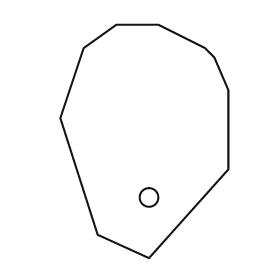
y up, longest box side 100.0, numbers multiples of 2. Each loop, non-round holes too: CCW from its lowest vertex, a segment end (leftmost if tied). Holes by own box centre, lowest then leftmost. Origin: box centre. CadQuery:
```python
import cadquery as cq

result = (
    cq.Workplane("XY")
    .moveTo(2.0, -50.0)
    .lineTo(36.0, -12.0)
    .lineTo(36.0, 22.0)
    .lineTo(30.0, 36.0)
    .lineTo(26.0, 40.0)
    .lineTo(6.0, 50.0)
    .lineTo(-12.0, 50.0)
    .lineTo(-26.0, 40.0)
    .lineTo(-36.0, 10.0)
    .lineTo(-20.0, -40.0)
    .close()
    .moveTo(2.0, -24.0)
    .circle(4.0)
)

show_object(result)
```